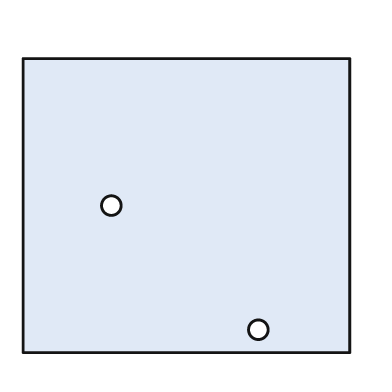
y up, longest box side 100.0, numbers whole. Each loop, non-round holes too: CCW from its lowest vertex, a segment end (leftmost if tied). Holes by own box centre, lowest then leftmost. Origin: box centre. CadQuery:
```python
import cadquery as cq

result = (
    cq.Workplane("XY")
    .moveTo(-50.0, -45.0)
    .lineTo(50.0, -45.0)
    .lineTo(50.0, 45.0)
    .lineTo(-50.0, 45.0)
    .close()
    .moveTo(22.0, -38.0)
    .circle(3.0)
    .moveTo(-23.0, 0.0)
    .circle(3.0)
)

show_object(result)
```